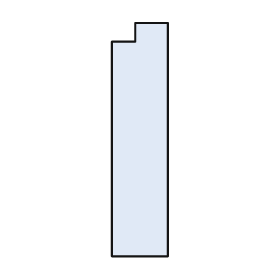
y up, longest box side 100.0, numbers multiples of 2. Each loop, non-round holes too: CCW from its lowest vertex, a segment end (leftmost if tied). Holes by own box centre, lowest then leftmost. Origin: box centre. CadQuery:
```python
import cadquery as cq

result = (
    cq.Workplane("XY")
    .moveTo(-12.0, -50.0)
    .lineTo(12.0, -50.0)
    .lineTo(12.0, 50.0)
    .lineTo(-2.0, 50.0)
    .lineTo(-2.0, 42.0)
    .lineTo(-12.0, 42.0)
    .close()
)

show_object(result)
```